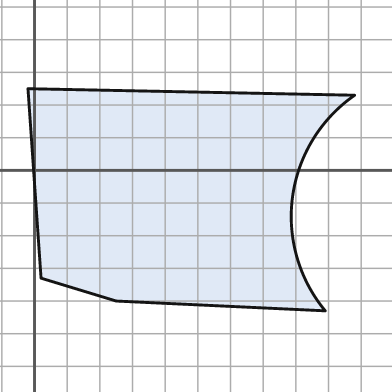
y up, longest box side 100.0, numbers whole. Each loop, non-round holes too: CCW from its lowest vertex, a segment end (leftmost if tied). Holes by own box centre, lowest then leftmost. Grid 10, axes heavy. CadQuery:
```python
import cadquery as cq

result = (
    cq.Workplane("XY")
    .moveTo(89.0, -43.0)
    .threePointArc((79.0, -8.0), (98.0, 23.0))
    .lineTo(-2.0, 25.0)
    .lineTo(2.0, -33.0)
    .lineTo(25.0, -40.0)
    .close()
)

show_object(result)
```